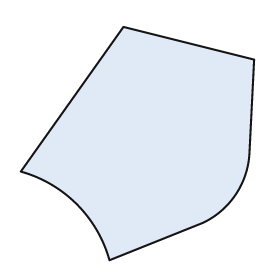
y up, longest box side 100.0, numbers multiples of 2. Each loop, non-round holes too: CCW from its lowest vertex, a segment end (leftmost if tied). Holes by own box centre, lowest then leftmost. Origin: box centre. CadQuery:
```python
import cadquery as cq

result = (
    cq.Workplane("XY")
    .moveTo(-12.0, -50.0)
    .lineTo(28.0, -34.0)
    .threePointArc((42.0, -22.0), (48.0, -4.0))
    .lineTo(50.0, 36.0)
    .lineTo(-6.0, 50.0)
    .lineTo(-50.0, -12.0)
    .threePointArc((-26.0, -26.0), (-12.0, -50.0))
    .close()
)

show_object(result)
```